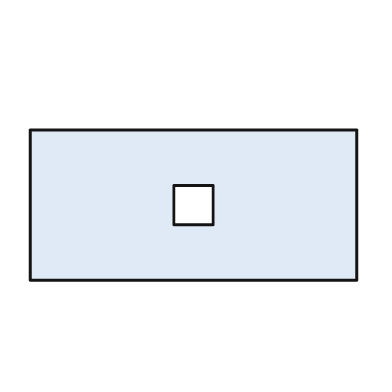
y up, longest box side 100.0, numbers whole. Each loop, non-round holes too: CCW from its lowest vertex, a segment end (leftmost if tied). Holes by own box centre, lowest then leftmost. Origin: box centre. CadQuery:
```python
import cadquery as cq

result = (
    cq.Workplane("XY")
    .moveTo(-50.0, -23.0)
    .lineTo(50.0, -23.0)
    .lineTo(50.0, 23.0)
    .lineTo(-50.0, 23.0)
    .close()
    .moveTo(-6.0, -6.0)
    .lineTo(6.0, -6.0)
    .lineTo(6.0, 6.0)
    .lineTo(-6.0, 6.0)
    .close()
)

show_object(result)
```